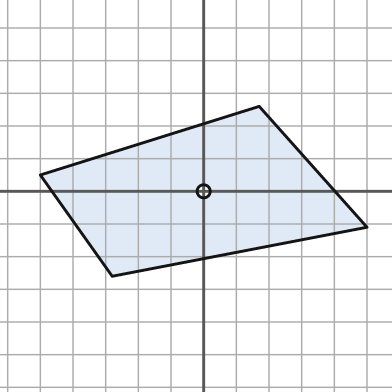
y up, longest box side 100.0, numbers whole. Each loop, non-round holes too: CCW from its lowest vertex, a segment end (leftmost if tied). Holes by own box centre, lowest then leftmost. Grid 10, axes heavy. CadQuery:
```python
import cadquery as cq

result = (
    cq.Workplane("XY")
    .moveTo(-28.0, -26.0)
    .lineTo(50.0, -11.0)
    .lineTo(17.0, 26.0)
    .lineTo(-50.0, 5.0)
    .close()
    .moveTo(0.0, 0.0)
    .circle(2.0)
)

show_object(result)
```